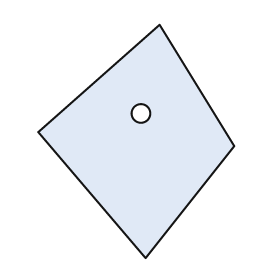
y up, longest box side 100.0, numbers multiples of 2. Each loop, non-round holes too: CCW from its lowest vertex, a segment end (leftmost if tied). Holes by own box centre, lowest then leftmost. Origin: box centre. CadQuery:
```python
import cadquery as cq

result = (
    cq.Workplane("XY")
    .moveTo(4.0, -50.0)
    .lineTo(42.0, -2.0)
    .lineTo(10.0, 50.0)
    .lineTo(-42.0, 4.0)
    .close()
    .moveTo(2.0, 12.0)
    .circle(4.0)
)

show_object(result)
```